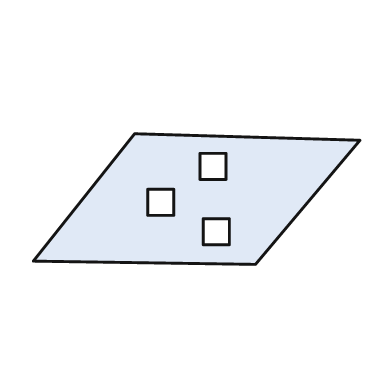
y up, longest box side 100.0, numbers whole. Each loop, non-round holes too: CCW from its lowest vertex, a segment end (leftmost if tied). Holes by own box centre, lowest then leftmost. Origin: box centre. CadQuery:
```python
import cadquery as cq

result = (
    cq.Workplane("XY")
    .moveTo(18.0, -20.0)
    .lineTo(50.0, 18.0)
    .lineTo(-19.0, 20.0)
    .lineTo(-50.0, -19.0)
    .close()
    .moveTo(2.0, -14.0)
    .lineTo(10.0, -14.0)
    .lineTo(10.0, -6.0)
    .lineTo(2.0, -6.0)
    .close()
    .moveTo(-15.0, -5.0)
    .lineTo(-7.0, -5.0)
    .lineTo(-7.0, 3.0)
    .lineTo(-15.0, 3.0)
    .close()
    .moveTo(1.0, 6.0)
    .lineTo(9.0, 6.0)
    .lineTo(9.0, 14.0)
    .lineTo(1.0, 14.0)
    .close()
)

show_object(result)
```